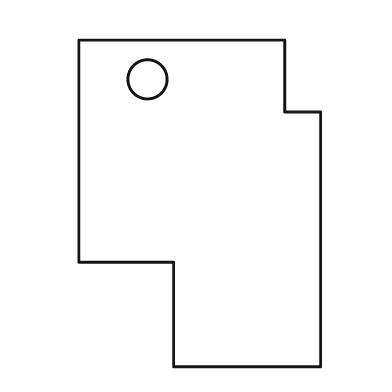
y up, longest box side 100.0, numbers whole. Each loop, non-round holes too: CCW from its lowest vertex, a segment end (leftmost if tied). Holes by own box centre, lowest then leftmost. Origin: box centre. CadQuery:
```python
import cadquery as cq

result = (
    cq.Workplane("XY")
    .moveTo(-8.0, -50.0)
    .lineTo(37.0, -50.0)
    .lineTo(37.0, 28.0)
    .lineTo(26.0, 28.0)
    .lineTo(26.0, 50.0)
    .lineTo(-37.0, 50.0)
    .lineTo(-37.0, -18.0)
    .lineTo(-8.0, -18.0)
    .close()
    .moveTo(-16.0, 38.0)
    .circle(6.0)
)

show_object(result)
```